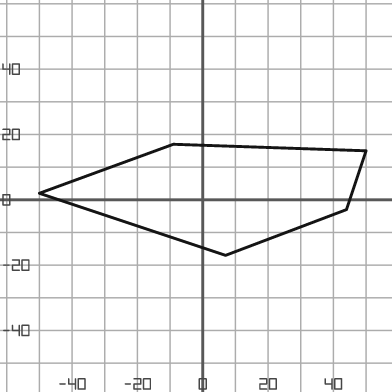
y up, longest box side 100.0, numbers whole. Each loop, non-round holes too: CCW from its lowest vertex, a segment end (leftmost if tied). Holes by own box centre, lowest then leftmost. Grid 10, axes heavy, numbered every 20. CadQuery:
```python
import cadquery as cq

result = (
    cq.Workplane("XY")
    .moveTo(7.0, -17.0)
    .lineTo(44.0, -3.0)
    .lineTo(50.0, 15.0)
    .lineTo(-9.0, 17.0)
    .lineTo(-50.0, 2.0)
    .close()
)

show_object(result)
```